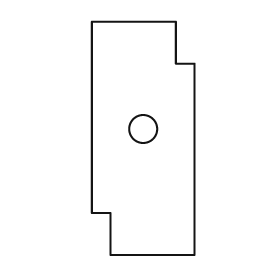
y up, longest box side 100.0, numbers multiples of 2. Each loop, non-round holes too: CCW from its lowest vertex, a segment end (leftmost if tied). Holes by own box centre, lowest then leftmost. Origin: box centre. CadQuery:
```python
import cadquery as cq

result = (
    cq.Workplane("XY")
    .moveTo(-14.0, -50.0)
    .lineTo(22.0, -50.0)
    .lineTo(22.0, 32.0)
    .lineTo(14.0, 32.0)
    .lineTo(14.0, 50.0)
    .lineTo(-22.0, 50.0)
    .lineTo(-22.0, -32.0)
    .lineTo(-14.0, -32.0)
    .close()
    .moveTo(0.0, 4.0)
    .circle(6.0)
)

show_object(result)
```